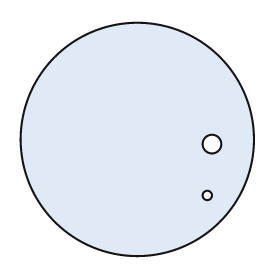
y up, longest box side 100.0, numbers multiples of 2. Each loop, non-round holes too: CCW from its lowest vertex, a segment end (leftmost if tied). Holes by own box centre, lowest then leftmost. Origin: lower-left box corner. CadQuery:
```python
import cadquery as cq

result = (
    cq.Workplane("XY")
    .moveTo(50.0, 50.0)
    .circle(50.0)
    .moveTo(80.0, 26.0)
    .circle(2.0)
    .moveTo(82.0, 48.0)
    .circle(4.0)
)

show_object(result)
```